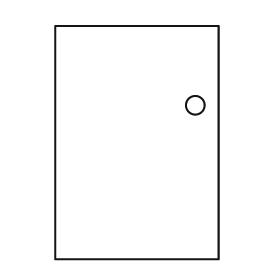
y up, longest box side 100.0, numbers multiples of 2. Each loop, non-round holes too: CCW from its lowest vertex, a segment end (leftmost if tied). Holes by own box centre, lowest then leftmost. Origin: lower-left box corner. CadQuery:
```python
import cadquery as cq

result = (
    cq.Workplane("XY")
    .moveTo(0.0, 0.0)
    .lineTo(70.0, 0.0)
    .lineTo(70.0, 100.0)
    .lineTo(0.0, 100.0)
    .close()
    .moveTo(60.0, 66.0)
    .circle(4.0)
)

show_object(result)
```